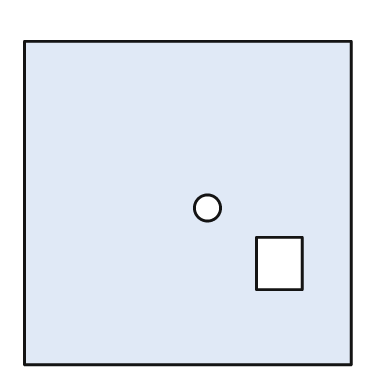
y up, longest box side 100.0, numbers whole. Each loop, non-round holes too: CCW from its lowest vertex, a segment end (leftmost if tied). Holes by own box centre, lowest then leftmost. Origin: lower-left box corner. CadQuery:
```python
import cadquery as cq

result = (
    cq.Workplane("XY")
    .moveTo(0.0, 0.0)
    .lineTo(100.0, 0.0)
    .lineTo(100.0, 99.0)
    .lineTo(0.0, 99.0)
    .close()
    .moveTo(71.0, 23.0)
    .lineTo(85.0, 23.0)
    .lineTo(85.0, 39.0)
    .lineTo(71.0, 39.0)
    .close()
    .moveTo(56.0, 48.0)
    .circle(4.0)
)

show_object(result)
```